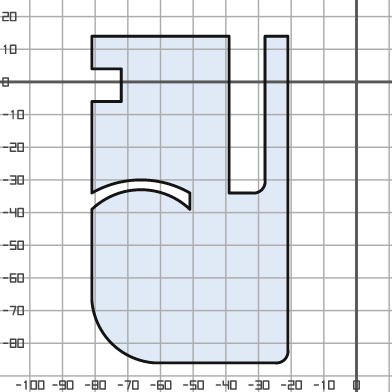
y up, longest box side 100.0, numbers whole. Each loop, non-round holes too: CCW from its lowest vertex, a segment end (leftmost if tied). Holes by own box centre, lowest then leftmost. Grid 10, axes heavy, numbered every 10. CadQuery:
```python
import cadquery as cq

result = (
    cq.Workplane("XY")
    .moveTo(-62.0, -86.0)
    .lineTo(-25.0, -86.0)
    .threePointArc((-22.0, -85.0), (-21.0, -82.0))
    .lineTo(-21.0, 14.0)
    .lineTo(-28.0, 14.0)
    .lineTo(-28.0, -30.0)
    .threePointArc((-29.0, -33.0), (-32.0, -34.0))
    .lineTo(-39.0, -34.0)
    .lineTo(-39.0, 14.0)
    .lineTo(-81.0, 14.0)
    .lineTo(-81.0, 4.0)
    .lineTo(-72.0, 4.0)
    .lineTo(-72.0, -6.0)
    .lineTo(-81.0, -6.0)
    .lineTo(-81.0, -34.0)
    .threePointArc((-66.0, -30.0), (-51.0, -34.0))
    .lineTo(-51.0, -39.0)
    .threePointArc((-66.0, -33.0), (-81.0, -39.0))
    .lineTo(-81.0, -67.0)
    .threePointArc((-75.0, -80.0), (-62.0, -86.0))
    .close()
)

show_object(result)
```